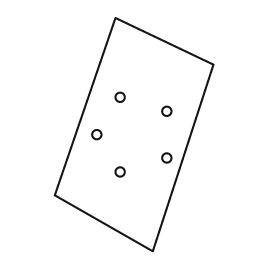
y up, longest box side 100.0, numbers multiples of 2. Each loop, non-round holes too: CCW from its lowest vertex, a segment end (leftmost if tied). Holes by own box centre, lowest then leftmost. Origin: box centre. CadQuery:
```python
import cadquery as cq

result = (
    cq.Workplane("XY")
    .moveTo(8.0, -50.0)
    .lineTo(34.0, 30.0)
    .lineTo(-8.0, 50.0)
    .lineTo(-34.0, -26.0)
    .close()
    .moveTo(-6.0, -16.0)
    .circle(2.0)
    .moveTo(14.0, -10.0)
    .circle(2.0)
    .moveTo(-16.0, 0.0)
    .circle(2.0)
    .moveTo(14.0, 10.0)
    .circle(2.0)
    .moveTo(-6.0, 16.0)
    .circle(2.0)
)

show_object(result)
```